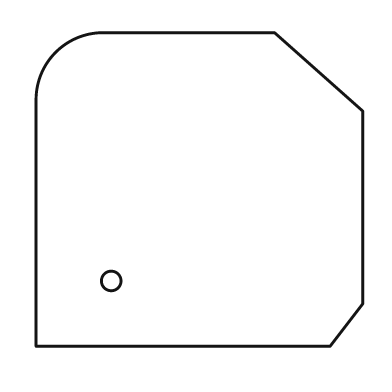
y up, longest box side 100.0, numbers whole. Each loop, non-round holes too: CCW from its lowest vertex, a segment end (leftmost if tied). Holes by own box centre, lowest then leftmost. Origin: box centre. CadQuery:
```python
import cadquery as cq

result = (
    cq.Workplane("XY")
    .moveTo(-50.0, -48.0)
    .lineTo(40.0, -48.0)
    .lineTo(50.0, -35.0)
    .lineTo(50.0, 24.0)
    .lineTo(23.0, 48.0)
    .lineTo(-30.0, 48.0)
    .threePointArc((-44.0, 42.0), (-50.0, 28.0))
    .close()
    .moveTo(-27.0, -28.0)
    .circle(3.0)
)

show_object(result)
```